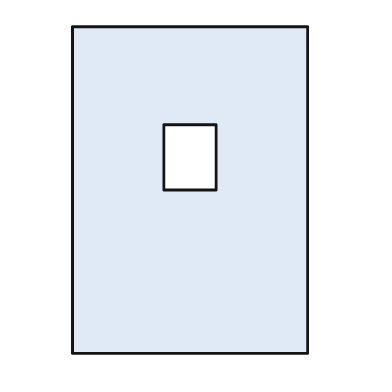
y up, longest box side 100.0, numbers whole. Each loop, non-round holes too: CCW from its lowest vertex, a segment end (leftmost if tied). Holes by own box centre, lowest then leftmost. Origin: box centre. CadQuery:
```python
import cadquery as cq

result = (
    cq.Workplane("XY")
    .moveTo(-36.0, -50.0)
    .lineTo(36.0, -50.0)
    .lineTo(36.0, 50.0)
    .lineTo(-36.0, 50.0)
    .close()
    .moveTo(-8.0, 0.0)
    .lineTo(8.0, 0.0)
    .lineTo(8.0, 20.0)
    .lineTo(-8.0, 20.0)
    .close()
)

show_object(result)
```